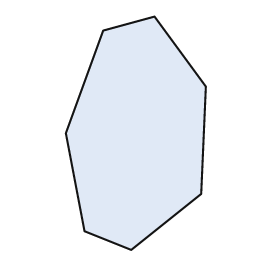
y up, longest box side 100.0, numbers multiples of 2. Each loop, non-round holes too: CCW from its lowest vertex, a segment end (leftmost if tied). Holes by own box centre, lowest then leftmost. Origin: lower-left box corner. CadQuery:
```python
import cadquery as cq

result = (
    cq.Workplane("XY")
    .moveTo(28.0, 0.0)
    .lineTo(58.0, 24.0)
    .lineTo(60.0, 70.0)
    .lineTo(38.0, 100.0)
    .lineTo(16.0, 94.0)
    .lineTo(0.0, 50.0)
    .lineTo(8.0, 8.0)
    .close()
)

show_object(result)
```